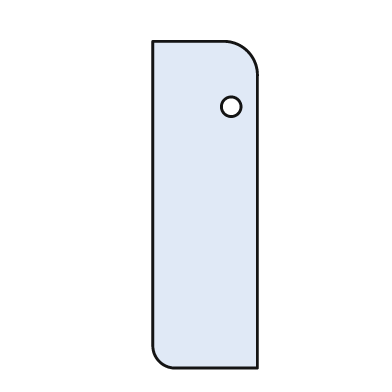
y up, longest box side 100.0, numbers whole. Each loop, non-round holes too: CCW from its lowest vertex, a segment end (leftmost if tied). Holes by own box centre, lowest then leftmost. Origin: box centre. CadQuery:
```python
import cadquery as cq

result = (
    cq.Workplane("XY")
    .moveTo(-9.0, -50.0)
    .lineTo(16.0, -50.0)
    .lineTo(16.0, 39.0)
    .threePointArc((13.0, 47.0), (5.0, 50.0))
    .lineTo(-16.0, 50.0)
    .lineTo(-16.0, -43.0)
    .threePointArc((-14.0, -48.0), (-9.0, -50.0))
    .close()
    .moveTo(8.0, 30.0)
    .circle(3.0)
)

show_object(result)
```